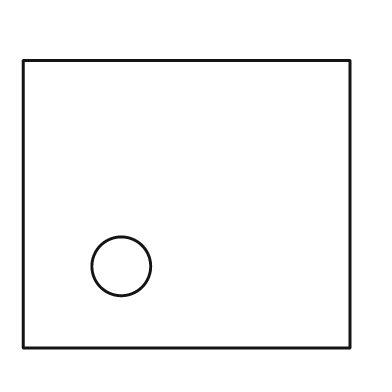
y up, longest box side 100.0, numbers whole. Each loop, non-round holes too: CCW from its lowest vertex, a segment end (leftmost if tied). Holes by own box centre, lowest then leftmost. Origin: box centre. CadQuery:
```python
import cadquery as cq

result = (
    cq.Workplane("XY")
    .moveTo(-50.0, -44.0)
    .lineTo(50.0, -44.0)
    .lineTo(50.0, 44.0)
    .lineTo(-50.0, 44.0)
    .close()
    .moveTo(-20.0, -19.0)
    .circle(9.0)
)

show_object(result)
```